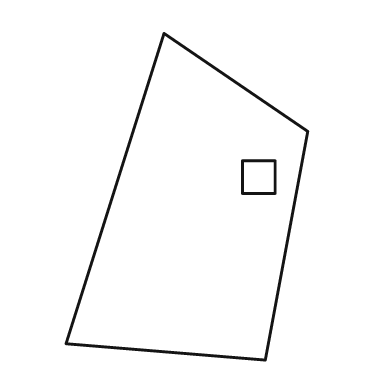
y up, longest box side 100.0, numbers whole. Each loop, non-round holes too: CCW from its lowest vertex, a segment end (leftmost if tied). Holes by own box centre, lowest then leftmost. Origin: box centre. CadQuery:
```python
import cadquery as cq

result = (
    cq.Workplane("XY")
    .moveTo(24.0, -50.0)
    .lineTo(37.0, 20.0)
    .lineTo(-7.0, 50.0)
    .lineTo(-37.0, -45.0)
    .close()
    .moveTo(17.0, 1.0)
    .lineTo(27.0, 1.0)
    .lineTo(27.0, 11.0)
    .lineTo(17.0, 11.0)
    .close()
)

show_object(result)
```